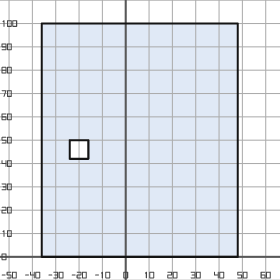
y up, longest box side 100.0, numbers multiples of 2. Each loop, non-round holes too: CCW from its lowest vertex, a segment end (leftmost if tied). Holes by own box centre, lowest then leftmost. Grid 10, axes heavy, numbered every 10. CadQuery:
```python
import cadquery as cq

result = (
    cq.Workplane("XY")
    .moveTo(-36.0, 0.0)
    .lineTo(48.0, 0.0)
    .lineTo(48.0, 100.0)
    .lineTo(-36.0, 100.0)
    .close()
    .moveTo(-24.0, 42.0)
    .lineTo(-16.0, 42.0)
    .lineTo(-16.0, 50.0)
    .lineTo(-24.0, 50.0)
    .close()
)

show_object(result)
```